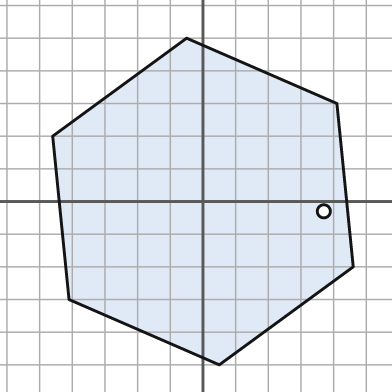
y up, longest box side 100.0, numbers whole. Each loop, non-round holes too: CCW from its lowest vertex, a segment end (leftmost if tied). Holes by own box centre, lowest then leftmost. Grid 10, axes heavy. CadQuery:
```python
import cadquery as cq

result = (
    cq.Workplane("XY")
    .moveTo(5.0, -50.0)
    .lineTo(46.0, -20.0)
    .lineTo(41.0, 30.0)
    .lineTo(-5.0, 50.0)
    .lineTo(-46.0, 20.0)
    .lineTo(-41.0, -30.0)
    .close()
    .moveTo(37.0, -3.0)
    .circle(2.0)
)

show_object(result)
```